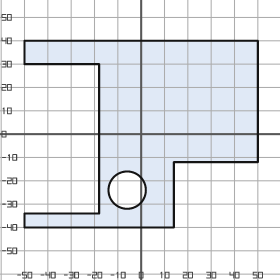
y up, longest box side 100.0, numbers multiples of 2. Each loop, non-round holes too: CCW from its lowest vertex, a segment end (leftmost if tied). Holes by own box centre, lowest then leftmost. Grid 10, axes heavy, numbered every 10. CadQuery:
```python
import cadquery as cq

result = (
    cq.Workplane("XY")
    .moveTo(-50.0, -40.0)
    .lineTo(14.0, -40.0)
    .lineTo(14.0, -12.0)
    .lineTo(50.0, -12.0)
    .lineTo(50.0, 40.0)
    .lineTo(-50.0, 40.0)
    .lineTo(-50.0, 30.0)
    .lineTo(-18.0, 30.0)
    .lineTo(-18.0, -34.0)
    .lineTo(-50.0, -34.0)
    .close()
    .moveTo(-6.0, -24.0)
    .circle(8.0)
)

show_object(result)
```